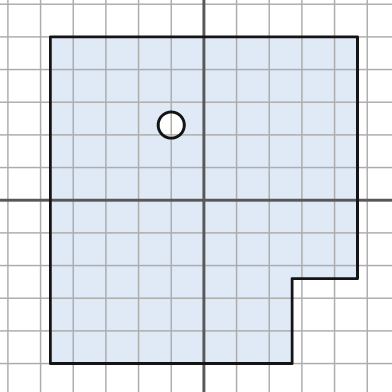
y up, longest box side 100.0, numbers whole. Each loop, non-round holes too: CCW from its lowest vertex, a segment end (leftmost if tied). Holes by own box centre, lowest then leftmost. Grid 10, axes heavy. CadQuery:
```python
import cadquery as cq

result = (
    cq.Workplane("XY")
    .moveTo(-47.0, -50.0)
    .lineTo(27.0, -50.0)
    .lineTo(27.0, -24.0)
    .lineTo(47.0, -24.0)
    .lineTo(47.0, 50.0)
    .lineTo(-47.0, 50.0)
    .close()
    .moveTo(-10.0, 23.0)
    .circle(4.0)
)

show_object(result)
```